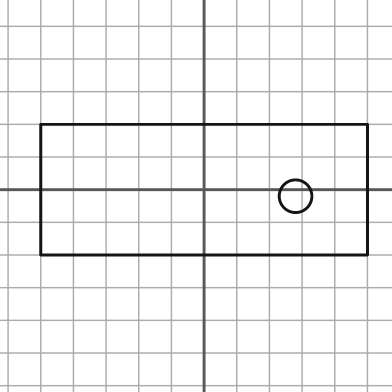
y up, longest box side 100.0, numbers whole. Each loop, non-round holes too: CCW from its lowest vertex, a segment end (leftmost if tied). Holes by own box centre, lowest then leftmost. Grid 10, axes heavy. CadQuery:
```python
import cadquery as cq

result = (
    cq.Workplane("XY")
    .moveTo(-50.0, -20.0)
    .lineTo(50.0, -20.0)
    .lineTo(50.0, 20.0)
    .lineTo(-50.0, 20.0)
    .close()
    .moveTo(28.0, -2.0)
    .circle(5.0)
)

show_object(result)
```